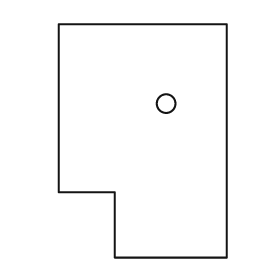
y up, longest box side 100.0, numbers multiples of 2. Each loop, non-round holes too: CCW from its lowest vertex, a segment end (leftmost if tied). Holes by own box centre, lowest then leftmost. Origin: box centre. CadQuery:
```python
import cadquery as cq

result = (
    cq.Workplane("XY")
    .moveTo(-12.0, -50.0)
    .lineTo(36.0, -50.0)
    .lineTo(36.0, 50.0)
    .lineTo(-36.0, 50.0)
    .lineTo(-36.0, -22.0)
    .lineTo(-12.0, -22.0)
    .close()
    .moveTo(10.0, 16.0)
    .circle(4.0)
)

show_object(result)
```